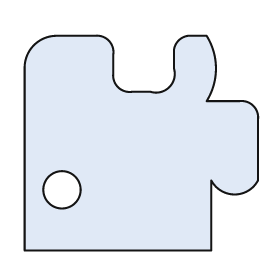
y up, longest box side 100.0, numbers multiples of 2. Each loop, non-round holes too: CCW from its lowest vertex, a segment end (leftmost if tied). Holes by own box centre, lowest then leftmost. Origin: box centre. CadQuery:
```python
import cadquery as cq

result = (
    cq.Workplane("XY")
    .moveTo(-50.0, -46.0)
    .lineTo(30.0, -46.0)
    .lineTo(30.0, -16.0)
    .threePointArc((40.0, -22.0), (50.0, -16.0))
    .lineTo(50.0, 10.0)
    .threePointArc((48.0, 16.0), (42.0, 18.0))
    .lineTo(28.0, 18.0)
    .threePointArc((32.0, 32.0), (28.0, 46.0))
    .lineTo(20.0, 46.0)
    .threePointArc((16.0, 44.0), (14.0, 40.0))
    .lineTo(14.0, 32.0)
    .threePointArc((12.0, 24.0), (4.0, 22.0))
    .lineTo(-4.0, 22.0)
    .threePointArc((-10.0, 24.0), (-12.0, 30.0))
    .lineTo(-12.0, 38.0)
    .threePointArc((-14.0, 44.0), (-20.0, 46.0))
    .lineTo(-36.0, 46.0)
    .threePointArc((-46.0, 42.0), (-50.0, 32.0))
    .close()
    .moveTo(-34.0, -20.0)
    .circle(8.0)
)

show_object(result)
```